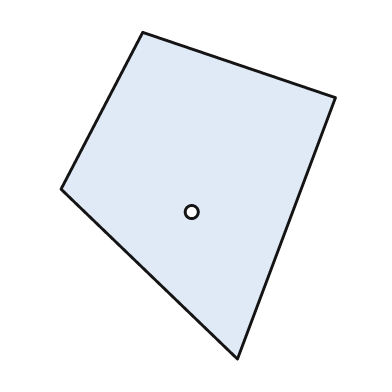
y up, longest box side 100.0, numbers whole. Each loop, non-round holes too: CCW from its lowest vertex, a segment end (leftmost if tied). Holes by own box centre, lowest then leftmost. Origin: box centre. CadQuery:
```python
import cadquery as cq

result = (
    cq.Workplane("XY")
    .moveTo(12.0, -50.0)
    .lineTo(42.0, 30.0)
    .lineTo(-17.0, 50.0)
    .lineTo(-42.0, 2.0)
    .close()
    .moveTo(-2.0, -5.0)
    .circle(2.0)
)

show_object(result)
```